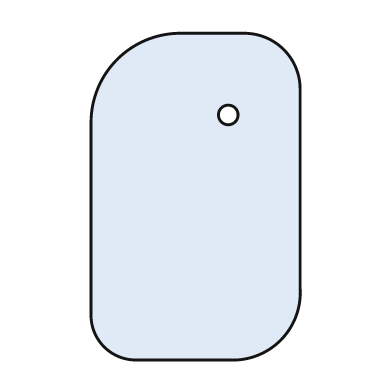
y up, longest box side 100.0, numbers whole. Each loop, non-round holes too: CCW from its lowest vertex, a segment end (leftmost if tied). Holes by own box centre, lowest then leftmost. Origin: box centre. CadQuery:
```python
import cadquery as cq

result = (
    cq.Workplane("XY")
    .moveTo(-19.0, -50.0)
    .lineTo(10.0, -50.0)
    .threePointArc((26.0, -44.0), (32.0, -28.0))
    .lineTo(32.0, 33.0)
    .threePointArc((27.0, 45.0), (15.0, 50.0))
    .lineTo(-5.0, 50.0)
    .threePointArc((-24.0, 42.0), (-32.0, 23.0))
    .lineTo(-32.0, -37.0)
    .threePointArc((-28.0, -46.0), (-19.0, -50.0))
    .close()
    .moveTo(10.0, 25.0)
    .circle(3.0)
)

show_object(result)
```